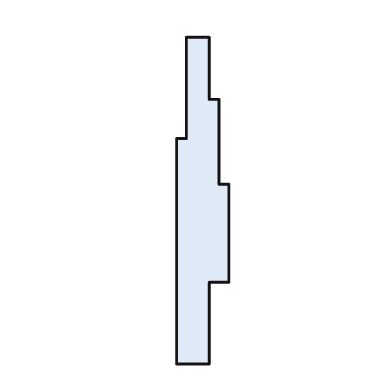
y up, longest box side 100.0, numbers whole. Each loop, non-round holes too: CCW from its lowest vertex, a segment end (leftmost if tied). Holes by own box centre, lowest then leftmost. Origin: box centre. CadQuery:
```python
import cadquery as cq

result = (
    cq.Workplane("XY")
    .moveTo(-8.0, -50.0)
    .lineTo(2.0, -50.0)
    .lineTo(2.0, -25.0)
    .lineTo(8.0, -25.0)
    .lineTo(8.0, 5.0)
    .lineTo(5.0, 5.0)
    .lineTo(5.0, 31.0)
    .lineTo(2.0, 31.0)
    .lineTo(2.0, 50.0)
    .lineTo(-5.0, 50.0)
    .lineTo(-5.0, 19.0)
    .lineTo(-8.0, 19.0)
    .close()
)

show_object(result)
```